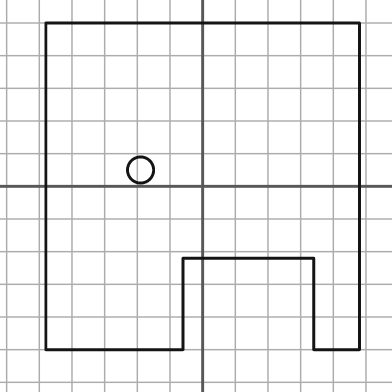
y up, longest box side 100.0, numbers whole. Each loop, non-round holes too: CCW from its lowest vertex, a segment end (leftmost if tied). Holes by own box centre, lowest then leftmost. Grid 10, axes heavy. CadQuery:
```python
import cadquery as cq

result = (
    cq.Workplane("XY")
    .moveTo(-48.0, -50.0)
    .lineTo(-6.0, -50.0)
    .lineTo(-6.0, -22.0)
    .lineTo(34.0, -22.0)
    .lineTo(34.0, -50.0)
    .lineTo(48.0, -50.0)
    .lineTo(48.0, 50.0)
    .lineTo(-48.0, 50.0)
    .close()
    .moveTo(-19.0, 5.0)
    .circle(4.0)
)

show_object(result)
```